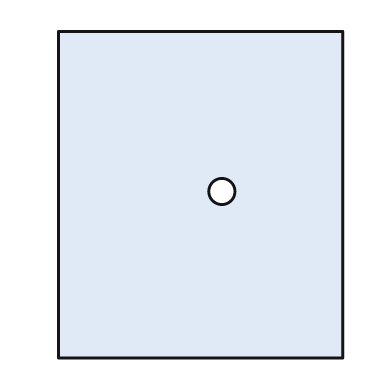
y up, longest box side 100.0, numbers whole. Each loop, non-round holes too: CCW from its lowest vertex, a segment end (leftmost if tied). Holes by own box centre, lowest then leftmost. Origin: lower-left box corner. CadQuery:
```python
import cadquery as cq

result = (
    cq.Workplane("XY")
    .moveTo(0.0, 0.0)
    .lineTo(87.0, 0.0)
    .lineTo(87.0, 100.0)
    .lineTo(0.0, 100.0)
    .close()
    .moveTo(50.0, 51.0)
    .circle(4.0)
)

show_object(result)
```